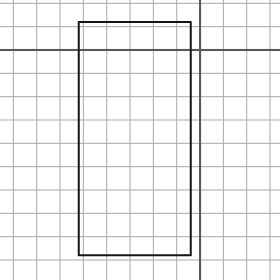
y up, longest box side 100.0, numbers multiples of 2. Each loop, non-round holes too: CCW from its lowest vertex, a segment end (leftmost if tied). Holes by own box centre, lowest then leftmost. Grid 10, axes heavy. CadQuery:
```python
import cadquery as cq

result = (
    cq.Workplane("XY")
    .moveTo(-52.0, -88.0)
    .lineTo(-4.0, -88.0)
    .lineTo(-4.0, 12.0)
    .lineTo(-52.0, 12.0)
    .close()
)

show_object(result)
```